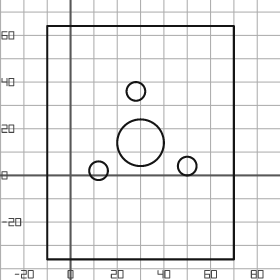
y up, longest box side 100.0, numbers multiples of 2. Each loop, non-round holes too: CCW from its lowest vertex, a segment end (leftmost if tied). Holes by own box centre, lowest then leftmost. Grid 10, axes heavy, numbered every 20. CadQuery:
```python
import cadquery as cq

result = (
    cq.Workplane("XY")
    .moveTo(-10.0, -36.0)
    .lineTo(70.0, -36.0)
    .lineTo(70.0, 64.0)
    .lineTo(-10.0, 64.0)
    .close()
    .moveTo(12.0, 2.0)
    .circle(4.0)
    .moveTo(50.0, 4.0)
    .circle(4.0)
    .moveTo(30.0, 14.0)
    .circle(10.0)
    .moveTo(28.0, 36.0)
    .circle(4.0)
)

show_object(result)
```